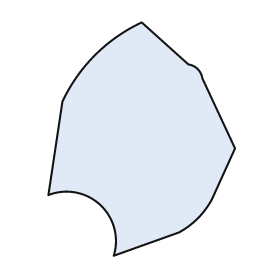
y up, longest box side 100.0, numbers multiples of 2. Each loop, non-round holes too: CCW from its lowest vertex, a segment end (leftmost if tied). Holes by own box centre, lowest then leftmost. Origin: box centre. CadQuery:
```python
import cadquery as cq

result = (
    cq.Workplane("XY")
    .moveTo(-12.0, -50.0)
    .lineTo(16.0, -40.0)
    .threePointArc((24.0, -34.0), (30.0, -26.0))
    .lineTo(40.0, -4.0)
    .lineTo(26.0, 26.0)
    .threePointArc((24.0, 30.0), (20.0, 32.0))
    .lineTo(0.0, 50.0)
    .threePointArc((-20.0, 36.0), (-34.0, 16.0))
    .lineTo(-40.0, -24.0)
    .threePointArc((-18.0, -28.0), (-12.0, -50.0))
    .close()
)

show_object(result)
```